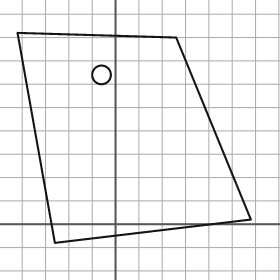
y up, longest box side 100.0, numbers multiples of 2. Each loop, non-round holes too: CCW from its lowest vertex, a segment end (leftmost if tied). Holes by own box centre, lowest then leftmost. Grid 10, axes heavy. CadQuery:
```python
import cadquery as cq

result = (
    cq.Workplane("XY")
    .moveTo(-26.0, -8.0)
    .lineTo(58.0, 2.0)
    .lineTo(26.0, 80.0)
    .lineTo(-42.0, 82.0)
    .close()
    .moveTo(-6.0, 64.0)
    .circle(4.0)
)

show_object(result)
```